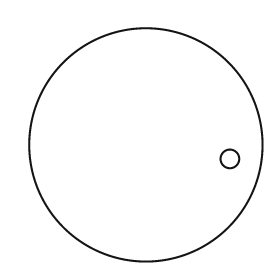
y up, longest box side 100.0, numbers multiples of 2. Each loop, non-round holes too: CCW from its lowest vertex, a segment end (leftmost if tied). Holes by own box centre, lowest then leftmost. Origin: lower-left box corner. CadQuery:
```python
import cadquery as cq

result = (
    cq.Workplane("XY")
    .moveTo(50.0, 50.0)
    .circle(50.0)
    .moveTo(86.0, 44.0)
    .circle(4.0)
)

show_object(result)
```